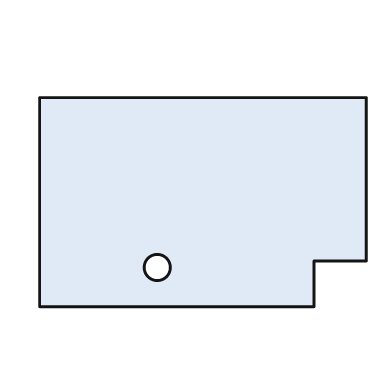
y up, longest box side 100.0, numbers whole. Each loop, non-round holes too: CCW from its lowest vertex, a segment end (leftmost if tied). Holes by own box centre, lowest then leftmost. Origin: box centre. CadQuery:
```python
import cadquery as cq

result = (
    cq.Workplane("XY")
    .moveTo(-50.0, -32.0)
    .lineTo(34.0, -32.0)
    .lineTo(34.0, -18.0)
    .lineTo(50.0, -18.0)
    .lineTo(50.0, 32.0)
    .lineTo(-50.0, 32.0)
    .close()
    .moveTo(-14.0, -20.0)
    .circle(4.0)
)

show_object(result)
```